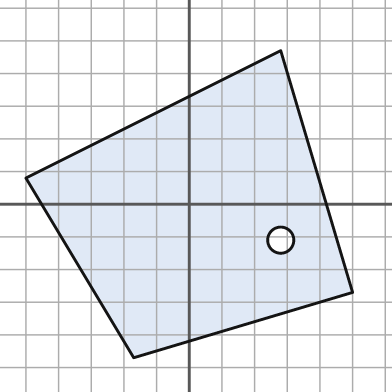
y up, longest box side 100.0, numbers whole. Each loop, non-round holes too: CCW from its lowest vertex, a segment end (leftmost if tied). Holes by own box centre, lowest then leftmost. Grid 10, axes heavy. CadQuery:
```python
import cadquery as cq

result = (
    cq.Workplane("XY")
    .moveTo(-17.0, -47.0)
    .lineTo(50.0, -27.0)
    .lineTo(28.0, 47.0)
    .lineTo(-50.0, 8.0)
    .close()
    .moveTo(28.0, -11.0)
    .circle(4.0)
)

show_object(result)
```